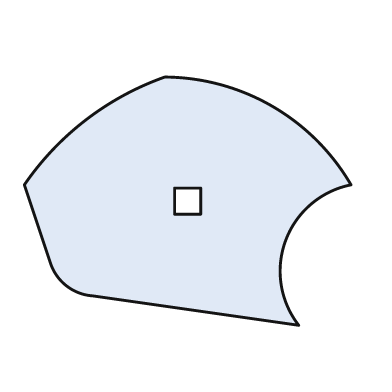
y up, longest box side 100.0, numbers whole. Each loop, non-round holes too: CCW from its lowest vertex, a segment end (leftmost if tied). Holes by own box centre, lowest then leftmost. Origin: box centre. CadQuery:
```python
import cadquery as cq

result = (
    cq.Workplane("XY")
    .moveTo(34.0, -38.0)
    .threePointArc((30.0, -12.0), (50.0, 5.0))
    .threePointArc((26.0, 29.0), (-7.0, 38.0))
    .threePointArc((-31.0, 25.0), (-50.0, 5.0))
    .lineTo(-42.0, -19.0)
    .threePointArc((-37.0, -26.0), (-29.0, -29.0))
    .close()
    .moveTo(-4.0, -4.0)
    .lineTo(4.0, -4.0)
    .lineTo(4.0, 4.0)
    .lineTo(-4.0, 4.0)
    .close()
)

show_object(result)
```